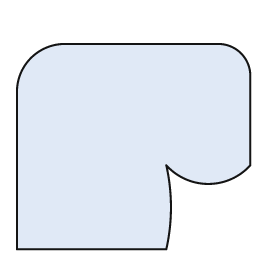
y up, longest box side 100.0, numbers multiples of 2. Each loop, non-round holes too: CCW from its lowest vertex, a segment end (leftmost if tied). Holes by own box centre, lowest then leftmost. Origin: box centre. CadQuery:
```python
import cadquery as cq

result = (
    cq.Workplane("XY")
    .moveTo(-50.0, -44.0)
    .lineTo(14.0, -44.0)
    .threePointArc((16.0, -26.0), (14.0, -8.0))
    .threePointArc((32.0, -16.0), (50.0, -8.0))
    .lineTo(50.0, 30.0)
    .threePointArc((46.0, 40.0), (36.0, 44.0))
    .lineTo(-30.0, 44.0)
    .threePointArc((-44.0, 38.0), (-50.0, 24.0))
    .close()
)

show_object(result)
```